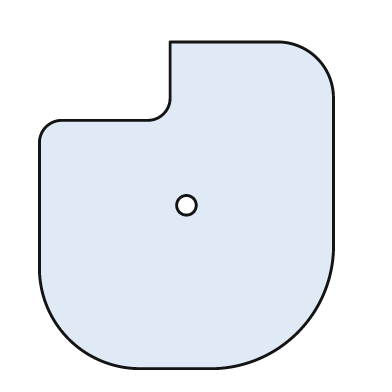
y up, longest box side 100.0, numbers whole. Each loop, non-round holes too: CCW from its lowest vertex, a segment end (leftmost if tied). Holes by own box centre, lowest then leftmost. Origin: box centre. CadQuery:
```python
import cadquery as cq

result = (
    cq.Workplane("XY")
    .moveTo(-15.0, -50.0)
    .lineTo(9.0, -50.0)
    .threePointArc((34.0, -39.0), (45.0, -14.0))
    .lineTo(45.0, 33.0)
    .threePointArc((40.0, 45.0), (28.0, 50.0))
    .lineTo(-5.0, 50.0)
    .lineTo(-5.0, 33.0)
    .threePointArc((-7.0, 28.0), (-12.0, 26.0))
    .lineTo(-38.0, 26.0)
    .threePointArc((-43.0, 24.0), (-45.0, 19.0))
    .lineTo(-45.0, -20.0)
    .threePointArc((-36.0, -41.0), (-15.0, -50.0))
    .close()
    .moveTo(0.0, 0.0)
    .circle(3.0)
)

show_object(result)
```